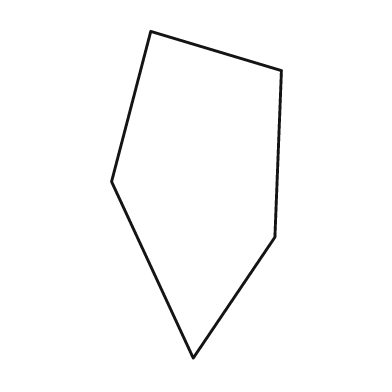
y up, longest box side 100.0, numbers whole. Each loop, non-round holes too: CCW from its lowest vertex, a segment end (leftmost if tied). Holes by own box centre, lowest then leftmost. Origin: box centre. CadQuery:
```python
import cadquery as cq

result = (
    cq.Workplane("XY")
    .moveTo(-1.0, -50.0)
    .lineTo(24.0, -13.0)
    .lineTo(26.0, 38.0)
    .lineTo(-14.0, 50.0)
    .lineTo(-26.0, 4.0)
    .close()
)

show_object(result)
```